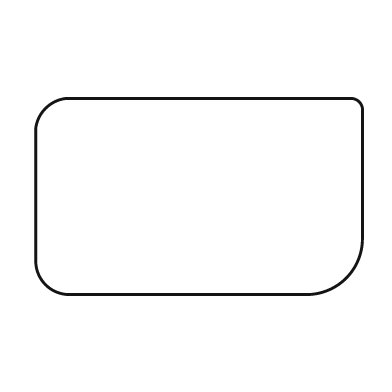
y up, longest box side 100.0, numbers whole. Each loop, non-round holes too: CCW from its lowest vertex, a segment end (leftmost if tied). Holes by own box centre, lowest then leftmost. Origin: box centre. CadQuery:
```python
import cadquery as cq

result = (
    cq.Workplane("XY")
    .moveTo(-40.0, -30.0)
    .lineTo(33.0, -30.0)
    .threePointArc((45.0, -25.0), (50.0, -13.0))
    .lineTo(50.0, 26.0)
    .threePointArc((49.0, 29.0), (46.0, 30.0))
    .lineTo(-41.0, 30.0)
    .threePointArc((-47.0, 27.0), (-50.0, 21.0))
    .lineTo(-50.0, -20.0)
    .threePointArc((-47.0, -27.0), (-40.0, -30.0))
    .close()
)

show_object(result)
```